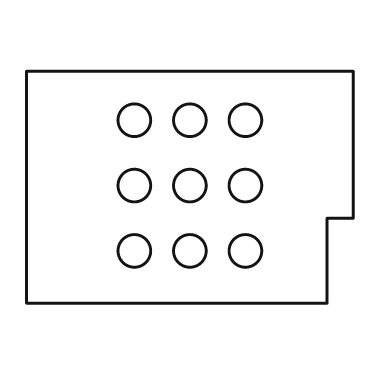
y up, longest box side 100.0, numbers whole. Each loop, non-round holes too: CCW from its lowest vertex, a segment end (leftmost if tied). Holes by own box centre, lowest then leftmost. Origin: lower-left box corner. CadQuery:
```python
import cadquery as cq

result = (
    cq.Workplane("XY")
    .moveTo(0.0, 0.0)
    .lineTo(92.0, 0.0)
    .lineTo(92.0, 26.0)
    .lineTo(100.0, 26.0)
    .lineTo(100.0, 71.0)
    .lineTo(0.0, 71.0)
    .close()
    .moveTo(33.0, 16.0)
    .circle(5.0)
    .moveTo(50.0, 16.0)
    .circle(5.0)
    .moveTo(67.0, 16.0)
    .circle(5.0)
    .moveTo(33.0, 36.0)
    .circle(5.0)
    .moveTo(50.0, 36.0)
    .circle(5.0)
    .moveTo(67.0, 36.0)
    .circle(5.0)
    .moveTo(33.0, 56.0)
    .circle(5.0)
    .moveTo(50.0, 56.0)
    .circle(5.0)
    .moveTo(67.0, 56.0)
    .circle(5.0)
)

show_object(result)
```